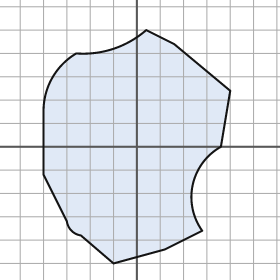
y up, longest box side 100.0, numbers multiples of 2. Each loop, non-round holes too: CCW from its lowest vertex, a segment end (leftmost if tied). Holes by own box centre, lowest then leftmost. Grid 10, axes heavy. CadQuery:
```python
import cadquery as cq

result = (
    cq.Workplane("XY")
    .moveTo(-10.0, -50.0)
    .lineTo(12.0, -44.0)
    .lineTo(28.0, -36.0)
    .threePointArc((24.0, -16.0), (36.0, 0.0))
    .lineTo(40.0, 24.0)
    .lineTo(16.0, 44.0)
    .lineTo(4.0, 50.0)
    .threePointArc((-10.0, 42.0), (-26.0, 40.0))
    .threePointArc((-36.0, 30.0), (-40.0, 16.0))
    .lineTo(-40.0, -12.0)
    .lineTo(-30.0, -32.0)
    .threePointArc((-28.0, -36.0), (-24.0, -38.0))
    .close()
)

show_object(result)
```